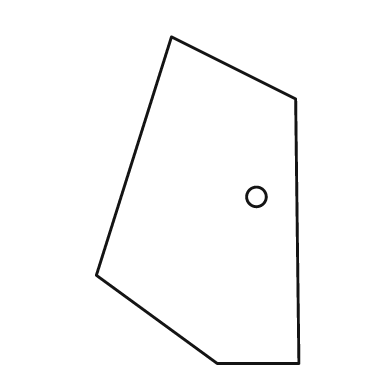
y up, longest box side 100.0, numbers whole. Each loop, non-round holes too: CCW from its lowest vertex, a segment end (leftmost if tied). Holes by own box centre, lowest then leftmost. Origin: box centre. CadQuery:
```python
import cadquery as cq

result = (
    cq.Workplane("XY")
    .moveTo(6.0, -50.0)
    .lineTo(31.0, -50.0)
    .lineTo(30.0, 31.0)
    .lineTo(-8.0, 50.0)
    .lineTo(-31.0, -23.0)
    .close()
    .moveTo(18.0, 1.0)
    .circle(3.0)
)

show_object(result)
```